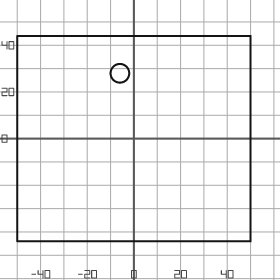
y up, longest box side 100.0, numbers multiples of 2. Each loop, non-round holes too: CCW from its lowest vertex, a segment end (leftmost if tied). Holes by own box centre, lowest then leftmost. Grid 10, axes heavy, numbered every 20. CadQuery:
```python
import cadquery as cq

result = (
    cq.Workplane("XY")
    .moveTo(-50.0, -44.0)
    .lineTo(50.0, -44.0)
    .lineTo(50.0, 44.0)
    .lineTo(-50.0, 44.0)
    .close()
    .moveTo(-6.0, 28.0)
    .circle(4.0)
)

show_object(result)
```